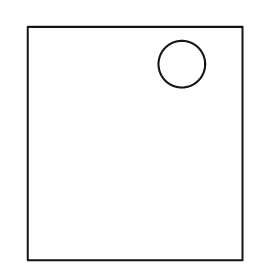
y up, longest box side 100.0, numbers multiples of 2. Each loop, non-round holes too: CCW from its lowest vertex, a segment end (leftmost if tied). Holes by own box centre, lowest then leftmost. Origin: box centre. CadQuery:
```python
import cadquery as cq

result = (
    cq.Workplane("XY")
    .moveTo(-46.0, -50.0)
    .lineTo(46.0, -50.0)
    .lineTo(46.0, 50.0)
    .lineTo(-46.0, 50.0)
    .close()
    .moveTo(20.0, 34.0)
    .circle(10.0)
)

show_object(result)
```